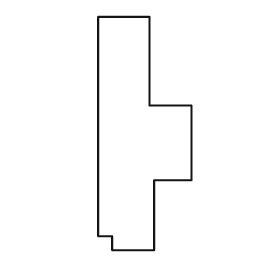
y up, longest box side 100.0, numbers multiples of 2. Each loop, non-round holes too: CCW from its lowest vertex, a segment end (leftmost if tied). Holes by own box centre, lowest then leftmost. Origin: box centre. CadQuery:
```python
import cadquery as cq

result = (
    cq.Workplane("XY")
    .moveTo(-14.0, -50.0)
    .lineTo(4.0, -50.0)
    .lineTo(4.0, -20.0)
    .lineTo(20.0, -20.0)
    .lineTo(20.0, 12.0)
    .lineTo(2.0, 12.0)
    .lineTo(2.0, 50.0)
    .lineTo(-20.0, 50.0)
    .lineTo(-20.0, -44.0)
    .lineTo(-14.0, -44.0)
    .close()
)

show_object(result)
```